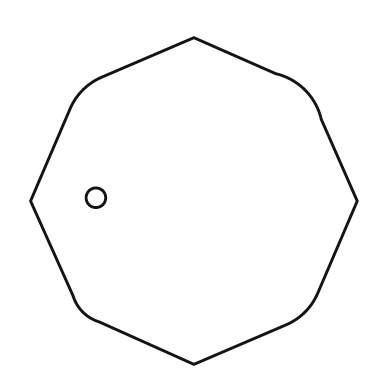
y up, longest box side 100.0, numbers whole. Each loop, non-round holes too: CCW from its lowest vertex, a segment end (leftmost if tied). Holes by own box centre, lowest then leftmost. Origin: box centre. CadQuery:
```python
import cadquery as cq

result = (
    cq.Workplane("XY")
    .moveTo(0.0, -50.0)
    .lineTo(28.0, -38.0)
    .threePointArc((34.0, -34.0), (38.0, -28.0))
    .lineTo(50.0, 0.0)
    .lineTo(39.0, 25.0)
    .threePointArc((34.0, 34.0), (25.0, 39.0))
    .lineTo(0.0, 50.0)
    .lineTo(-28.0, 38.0)
    .threePointArc((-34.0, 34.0), (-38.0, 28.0))
    .lineTo(-50.0, 0.0)
    .lineTo(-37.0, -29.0)
    .threePointArc((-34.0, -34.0), (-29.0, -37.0))
    .close()
    .moveTo(-30.0, 1.0)
    .circle(3.0)
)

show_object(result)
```